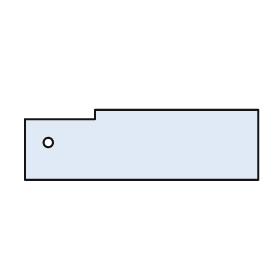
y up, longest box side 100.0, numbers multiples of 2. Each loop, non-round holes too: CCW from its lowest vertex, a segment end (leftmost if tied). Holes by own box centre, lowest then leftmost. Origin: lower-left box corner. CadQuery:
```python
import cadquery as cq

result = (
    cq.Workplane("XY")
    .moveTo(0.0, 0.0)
    .lineTo(100.0, 0.0)
    .lineTo(100.0, 30.0)
    .lineTo(30.0, 30.0)
    .lineTo(30.0, 26.0)
    .lineTo(0.0, 26.0)
    .close()
    .moveTo(10.0, 16.0)
    .circle(2.0)
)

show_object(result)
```